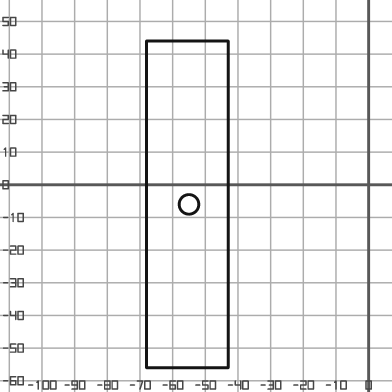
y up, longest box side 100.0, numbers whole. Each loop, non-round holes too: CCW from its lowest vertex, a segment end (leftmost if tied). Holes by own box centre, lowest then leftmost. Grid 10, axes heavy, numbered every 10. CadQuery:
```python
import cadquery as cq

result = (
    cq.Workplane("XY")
    .moveTo(-68.0, -56.0)
    .lineTo(-43.0, -56.0)
    .lineTo(-43.0, 44.0)
    .lineTo(-68.0, 44.0)
    .close()
    .moveTo(-55.0, -6.0)
    .circle(3.0)
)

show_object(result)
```